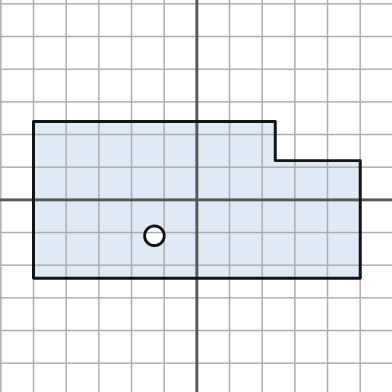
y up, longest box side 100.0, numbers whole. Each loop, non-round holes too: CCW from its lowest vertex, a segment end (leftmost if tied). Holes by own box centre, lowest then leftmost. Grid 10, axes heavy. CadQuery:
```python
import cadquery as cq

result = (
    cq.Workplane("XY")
    .moveTo(-50.0, -24.0)
    .lineTo(50.0, -24.0)
    .lineTo(50.0, 12.0)
    .lineTo(24.0, 12.0)
    .lineTo(24.0, 24.0)
    .lineTo(-50.0, 24.0)
    .close()
    .moveTo(-13.0, -11.0)
    .circle(3.0)
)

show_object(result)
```